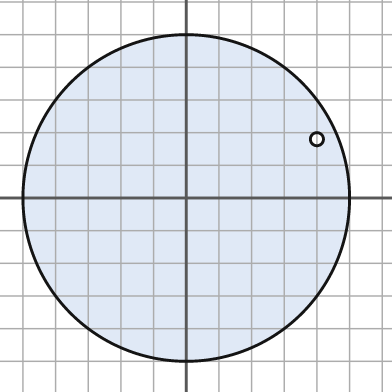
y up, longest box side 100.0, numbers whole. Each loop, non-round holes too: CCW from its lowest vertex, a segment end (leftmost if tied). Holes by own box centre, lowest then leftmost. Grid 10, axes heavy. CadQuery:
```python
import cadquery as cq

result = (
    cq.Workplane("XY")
    .moveTo(0.0, 0.0)
    .circle(50.0)
    .moveTo(40.0, 18.0)
    .circle(2.0)
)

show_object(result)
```